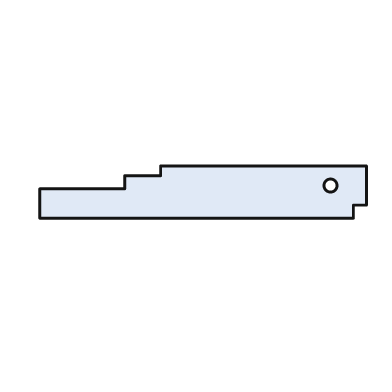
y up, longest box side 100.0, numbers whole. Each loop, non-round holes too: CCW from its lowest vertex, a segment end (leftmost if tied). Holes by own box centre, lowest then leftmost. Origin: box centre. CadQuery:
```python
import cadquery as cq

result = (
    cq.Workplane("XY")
    .moveTo(-50.0, -8.0)
    .lineTo(46.0, -8.0)
    .lineTo(46.0, -4.0)
    .lineTo(50.0, -4.0)
    .lineTo(50.0, 8.0)
    .lineTo(-13.0, 8.0)
    .lineTo(-13.0, 5.0)
    .lineTo(-24.0, 5.0)
    .lineTo(-24.0, 1.0)
    .lineTo(-50.0, 1.0)
    .close()
    .moveTo(39.0, 2.0)
    .circle(2.0)
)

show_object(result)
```